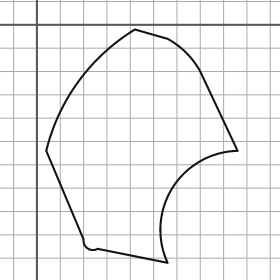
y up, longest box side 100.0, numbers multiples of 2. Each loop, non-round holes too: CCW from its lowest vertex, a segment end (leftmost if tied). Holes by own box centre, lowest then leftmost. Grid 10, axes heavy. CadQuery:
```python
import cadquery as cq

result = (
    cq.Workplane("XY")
    .moveTo(56.0, -102.0)
    .threePointArc((58.0, -70.0), (86.0, -54.0))
    .lineTo(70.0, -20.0)
    .threePointArc((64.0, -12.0), (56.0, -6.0))
    .lineTo(42.0, -2.0)
    .threePointArc((18.0, -24.0), (4.0, -54.0))
    .lineTo(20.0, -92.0)
    .threePointArc((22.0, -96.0), (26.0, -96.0))
    .close()
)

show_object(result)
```